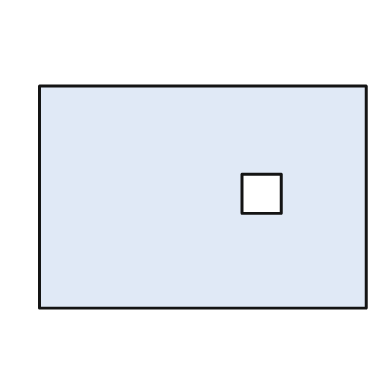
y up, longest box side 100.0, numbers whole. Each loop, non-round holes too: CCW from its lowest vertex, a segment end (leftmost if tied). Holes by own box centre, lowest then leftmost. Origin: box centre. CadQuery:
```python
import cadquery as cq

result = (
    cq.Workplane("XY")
    .moveTo(-50.0, -34.0)
    .lineTo(50.0, -34.0)
    .lineTo(50.0, 34.0)
    .lineTo(-50.0, 34.0)
    .close()
    .moveTo(12.0, -5.0)
    .lineTo(24.0, -5.0)
    .lineTo(24.0, 7.0)
    .lineTo(12.0, 7.0)
    .close()
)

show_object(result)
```